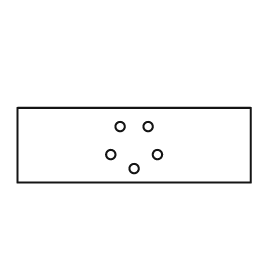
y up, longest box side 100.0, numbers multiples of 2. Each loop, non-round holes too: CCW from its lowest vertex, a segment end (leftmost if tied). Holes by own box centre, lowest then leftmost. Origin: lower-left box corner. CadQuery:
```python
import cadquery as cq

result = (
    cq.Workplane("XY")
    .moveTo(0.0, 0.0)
    .lineTo(100.0, 0.0)
    .lineTo(100.0, 32.0)
    .lineTo(0.0, 32.0)
    .close()
    .moveTo(50.0, 6.0)
    .circle(2.0)
    .moveTo(40.0, 12.0)
    .circle(2.0)
    .moveTo(60.0, 12.0)
    .circle(2.0)
    .moveTo(44.0, 24.0)
    .circle(2.0)
    .moveTo(56.0, 24.0)
    .circle(2.0)
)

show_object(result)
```